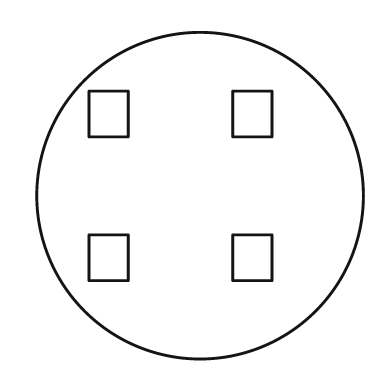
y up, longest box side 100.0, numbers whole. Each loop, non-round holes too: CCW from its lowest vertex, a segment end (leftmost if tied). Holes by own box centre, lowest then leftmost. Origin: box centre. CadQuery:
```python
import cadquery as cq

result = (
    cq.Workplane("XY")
    .moveTo(0.0, 0.0)
    .circle(50.0)
    .moveTo(-34.0, -26.0)
    .lineTo(-22.0, -26.0)
    .lineTo(-22.0, -12.0)
    .lineTo(-34.0, -12.0)
    .close()
    .moveTo(10.0, -26.0)
    .lineTo(22.0, -26.0)
    .lineTo(22.0, -12.0)
    .lineTo(10.0, -12.0)
    .close()
    .moveTo(-34.0, 18.0)
    .lineTo(-22.0, 18.0)
    .lineTo(-22.0, 32.0)
    .lineTo(-34.0, 32.0)
    .close()
    .moveTo(10.0, 18.0)
    .lineTo(22.0, 18.0)
    .lineTo(22.0, 32.0)
    .lineTo(10.0, 32.0)
    .close()
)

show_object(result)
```